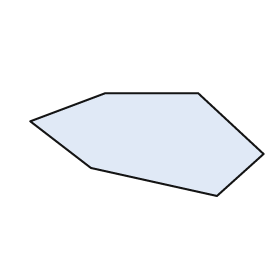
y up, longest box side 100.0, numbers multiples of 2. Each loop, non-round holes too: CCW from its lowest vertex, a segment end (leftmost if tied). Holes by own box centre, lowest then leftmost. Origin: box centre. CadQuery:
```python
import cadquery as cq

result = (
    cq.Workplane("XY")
    .moveTo(30.0, -22.0)
    .lineTo(50.0, -4.0)
    .lineTo(22.0, 22.0)
    .lineTo(-18.0, 22.0)
    .lineTo(-50.0, 10.0)
    .lineTo(-24.0, -10.0)
    .close()
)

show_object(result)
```